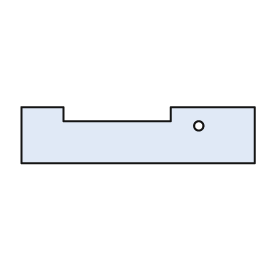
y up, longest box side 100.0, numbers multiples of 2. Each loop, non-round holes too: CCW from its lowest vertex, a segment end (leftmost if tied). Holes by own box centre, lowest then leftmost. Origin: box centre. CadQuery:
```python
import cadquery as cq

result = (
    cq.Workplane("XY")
    .moveTo(-50.0, -12.0)
    .lineTo(50.0, -12.0)
    .lineTo(50.0, 12.0)
    .lineTo(14.0, 12.0)
    .lineTo(14.0, 6.0)
    .lineTo(-32.0, 6.0)
    .lineTo(-32.0, 12.0)
    .lineTo(-50.0, 12.0)
    .close()
    .moveTo(26.0, 4.0)
    .circle(2.0)
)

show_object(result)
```